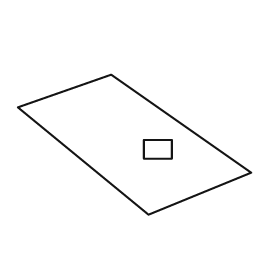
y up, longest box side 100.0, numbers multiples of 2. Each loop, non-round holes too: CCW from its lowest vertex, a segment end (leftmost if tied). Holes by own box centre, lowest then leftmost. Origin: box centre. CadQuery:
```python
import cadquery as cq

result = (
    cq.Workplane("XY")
    .moveTo(6.0, -30.0)
    .lineTo(50.0, -12.0)
    .lineTo(-10.0, 30.0)
    .lineTo(-50.0, 16.0)
    .close()
    .moveTo(4.0, -6.0)
    .lineTo(16.0, -6.0)
    .lineTo(16.0, 2.0)
    .lineTo(4.0, 2.0)
    .close()
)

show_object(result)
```